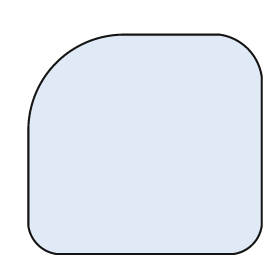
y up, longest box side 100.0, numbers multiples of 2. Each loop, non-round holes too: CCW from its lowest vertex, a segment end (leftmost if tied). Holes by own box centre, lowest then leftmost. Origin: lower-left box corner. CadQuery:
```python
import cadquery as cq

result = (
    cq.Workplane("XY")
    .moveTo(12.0, 0.0)
    .lineTo(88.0, 0.0)
    .threePointArc((96.0, 4.0), (100.0, 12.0))
    .lineTo(100.0, 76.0)
    .threePointArc((94.0, 88.0), (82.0, 94.0))
    .lineTo(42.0, 94.0)
    .threePointArc((12.0, 82.0), (0.0, 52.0))
    .lineTo(0.0, 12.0)
    .threePointArc((4.0, 4.0), (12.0, 0.0))
    .close()
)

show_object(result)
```